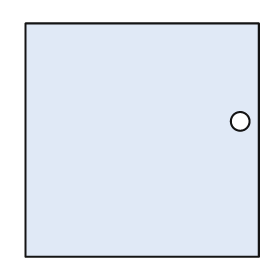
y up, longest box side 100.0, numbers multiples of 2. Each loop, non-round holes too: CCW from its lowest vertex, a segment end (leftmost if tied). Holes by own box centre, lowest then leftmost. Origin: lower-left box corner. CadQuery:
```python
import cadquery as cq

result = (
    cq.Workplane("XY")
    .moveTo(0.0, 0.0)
    .lineTo(100.0, 0.0)
    .lineTo(100.0, 100.0)
    .lineTo(0.0, 100.0)
    .close()
    .moveTo(92.0, 58.0)
    .circle(4.0)
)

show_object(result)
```